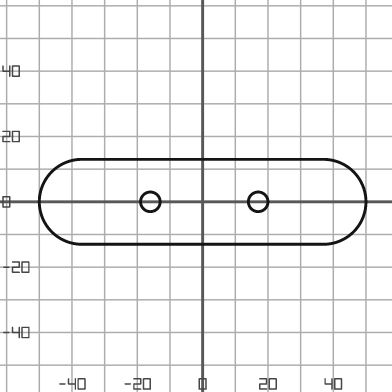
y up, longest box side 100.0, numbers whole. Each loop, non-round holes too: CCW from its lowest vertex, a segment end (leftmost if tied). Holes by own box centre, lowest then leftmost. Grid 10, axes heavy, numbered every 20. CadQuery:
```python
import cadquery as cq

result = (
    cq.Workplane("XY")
    .moveTo(-37.0, -13.0)
    .lineTo(37.0, -13.0)
    .threePointArc((50.0, 0.0), (37.0, 13.0))
    .lineTo(-37.0, 13.0)
    .threePointArc((-50.0, 0.0), (-37.0, -13.0))
    .close()
    .moveTo(-16.0, 0.0)
    .circle(3.0)
    .moveTo(17.0, 0.0)
    .circle(3.0)
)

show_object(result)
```